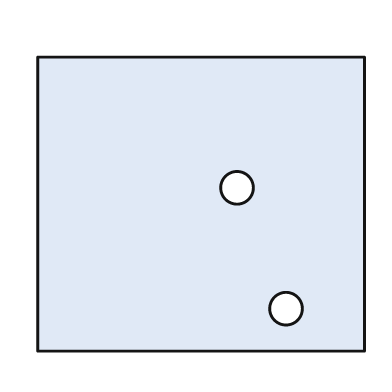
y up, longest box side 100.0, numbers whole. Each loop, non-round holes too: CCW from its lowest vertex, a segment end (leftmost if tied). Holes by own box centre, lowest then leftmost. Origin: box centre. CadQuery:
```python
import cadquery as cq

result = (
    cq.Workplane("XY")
    .moveTo(-50.0, -45.0)
    .lineTo(50.0, -45.0)
    .lineTo(50.0, 45.0)
    .lineTo(-50.0, 45.0)
    .close()
    .moveTo(26.0, -32.0)
    .circle(5.0)
    .moveTo(11.0, 5.0)
    .circle(5.0)
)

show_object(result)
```